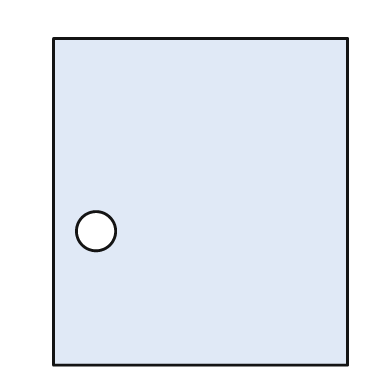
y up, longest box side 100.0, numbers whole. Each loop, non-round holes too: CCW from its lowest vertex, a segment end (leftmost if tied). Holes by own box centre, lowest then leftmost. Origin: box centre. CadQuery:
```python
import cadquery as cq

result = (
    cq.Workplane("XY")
    .moveTo(-45.0, -50.0)
    .lineTo(45.0, -50.0)
    .lineTo(45.0, 50.0)
    .lineTo(-45.0, 50.0)
    .close()
    .moveTo(-32.0, -9.0)
    .circle(6.0)
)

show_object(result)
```